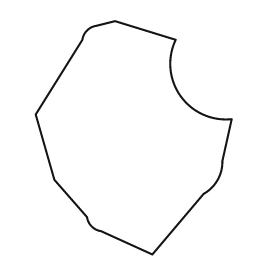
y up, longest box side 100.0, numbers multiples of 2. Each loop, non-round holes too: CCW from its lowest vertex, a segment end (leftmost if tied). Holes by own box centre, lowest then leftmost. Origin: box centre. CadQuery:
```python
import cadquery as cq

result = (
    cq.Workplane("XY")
    .moveTo(8.0, -50.0)
    .lineTo(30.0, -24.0)
    .threePointArc((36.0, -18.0), (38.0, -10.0))
    .lineTo(42.0, 8.0)
    .threePointArc((20.0, 18.0), (18.0, 42.0))
    .lineTo(-8.0, 50.0)
    .lineTo(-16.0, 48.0)
    .threePointArc((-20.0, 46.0), (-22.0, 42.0))
    .lineTo(-42.0, 10.0)
    .lineTo(-34.0, -18.0)
    .lineTo(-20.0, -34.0)
    .threePointArc((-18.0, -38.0), (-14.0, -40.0))
    .close()
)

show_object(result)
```